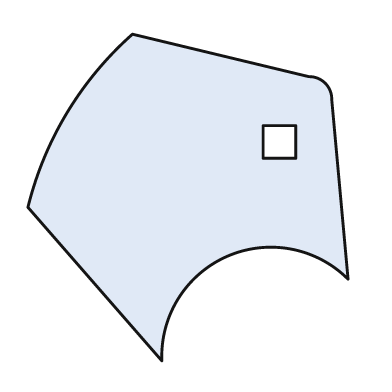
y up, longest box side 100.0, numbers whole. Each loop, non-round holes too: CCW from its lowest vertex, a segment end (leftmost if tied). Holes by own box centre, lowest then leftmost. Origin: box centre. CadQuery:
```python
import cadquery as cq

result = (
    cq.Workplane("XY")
    .moveTo(-8.0, -50.0)
    .threePointArc((12.0, -18.0), (49.0, -25.0))
    .lineTo(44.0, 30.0)
    .threePointArc((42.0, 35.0), (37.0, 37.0))
    .lineTo(-17.0, 50.0)
    .threePointArc((-37.0, 26.0), (-49.0, -3.0))
    .close()
    .moveTo(23.0, 12.0)
    .lineTo(33.0, 12.0)
    .lineTo(33.0, 22.0)
    .lineTo(23.0, 22.0)
    .close()
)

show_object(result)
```